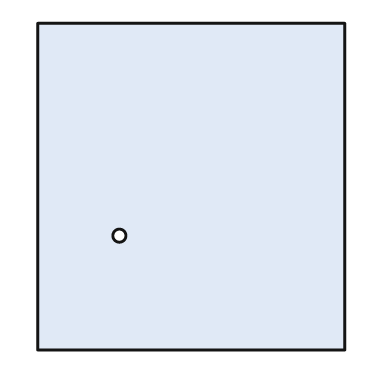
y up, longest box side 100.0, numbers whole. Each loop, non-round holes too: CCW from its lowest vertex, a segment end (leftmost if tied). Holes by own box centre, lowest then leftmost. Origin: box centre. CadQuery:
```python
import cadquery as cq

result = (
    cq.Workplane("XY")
    .moveTo(-47.0, -50.0)
    .lineTo(47.0, -50.0)
    .lineTo(47.0, 50.0)
    .lineTo(-47.0, 50.0)
    .close()
    .moveTo(-22.0, -15.0)
    .circle(2.0)
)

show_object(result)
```